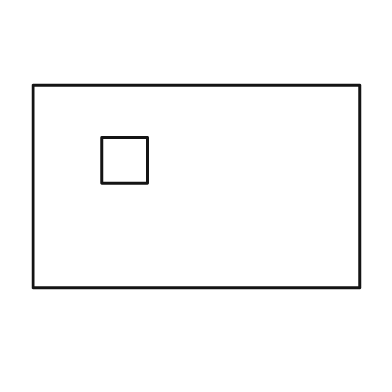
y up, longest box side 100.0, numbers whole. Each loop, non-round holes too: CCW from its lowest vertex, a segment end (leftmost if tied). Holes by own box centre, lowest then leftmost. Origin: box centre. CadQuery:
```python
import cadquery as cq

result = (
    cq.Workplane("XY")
    .moveTo(-50.0, -31.0)
    .lineTo(50.0, -31.0)
    .lineTo(50.0, 31.0)
    .lineTo(-50.0, 31.0)
    .close()
    .moveTo(-29.0, 1.0)
    .lineTo(-15.0, 1.0)
    .lineTo(-15.0, 15.0)
    .lineTo(-29.0, 15.0)
    .close()
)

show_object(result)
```